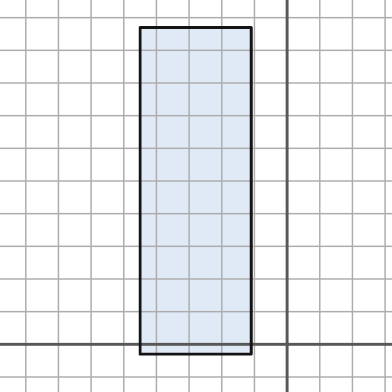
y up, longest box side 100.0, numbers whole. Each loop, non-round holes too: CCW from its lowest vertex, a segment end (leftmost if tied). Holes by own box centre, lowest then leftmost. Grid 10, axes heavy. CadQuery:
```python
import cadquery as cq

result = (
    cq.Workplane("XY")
    .moveTo(-45.0, -3.0)
    .lineTo(-11.0, -3.0)
    .lineTo(-11.0, 97.0)
    .lineTo(-45.0, 97.0)
    .close()
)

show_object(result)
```